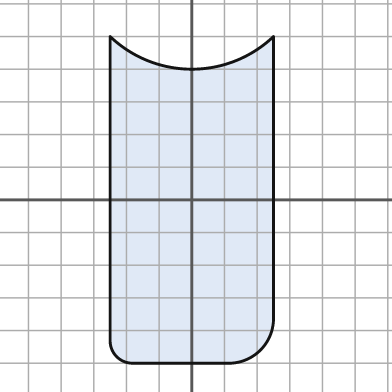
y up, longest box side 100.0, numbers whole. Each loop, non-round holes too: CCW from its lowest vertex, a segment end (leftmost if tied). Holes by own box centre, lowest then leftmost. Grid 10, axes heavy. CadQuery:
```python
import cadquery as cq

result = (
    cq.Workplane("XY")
    .moveTo(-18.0, -50.0)
    .lineTo(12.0, -50.0)
    .threePointArc((21.0, -46.0), (25.0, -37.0))
    .lineTo(25.0, 50.0)
    .threePointArc((0.0, 40.0), (-25.0, 50.0))
    .lineTo(-25.0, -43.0)
    .threePointArc((-23.0, -48.0), (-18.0, -50.0))
    .close()
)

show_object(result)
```